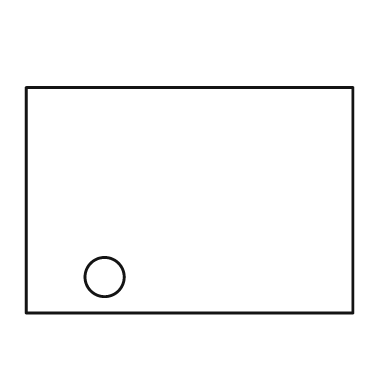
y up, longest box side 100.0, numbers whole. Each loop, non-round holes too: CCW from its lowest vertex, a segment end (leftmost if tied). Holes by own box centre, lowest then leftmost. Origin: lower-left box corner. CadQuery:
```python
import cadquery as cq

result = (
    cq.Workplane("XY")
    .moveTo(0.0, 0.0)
    .lineTo(100.0, 0.0)
    .lineTo(100.0, 69.0)
    .lineTo(0.0, 69.0)
    .close()
    .moveTo(24.0, 11.0)
    .circle(6.0)
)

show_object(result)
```